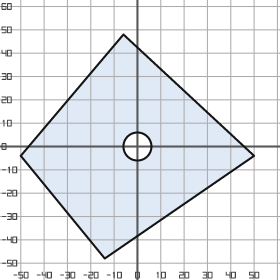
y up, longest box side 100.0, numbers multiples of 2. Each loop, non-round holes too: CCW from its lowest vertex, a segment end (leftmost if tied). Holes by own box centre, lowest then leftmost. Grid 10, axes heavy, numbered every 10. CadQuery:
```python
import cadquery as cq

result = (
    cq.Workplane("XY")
    .moveTo(-14.0, -48.0)
    .lineTo(50.0, -4.0)
    .lineTo(-6.0, 48.0)
    .lineTo(-50.0, -4.0)
    .close()
    .moveTo(0.0, 0.0)
    .circle(6.0)
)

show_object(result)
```